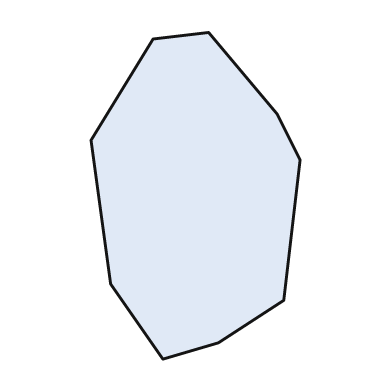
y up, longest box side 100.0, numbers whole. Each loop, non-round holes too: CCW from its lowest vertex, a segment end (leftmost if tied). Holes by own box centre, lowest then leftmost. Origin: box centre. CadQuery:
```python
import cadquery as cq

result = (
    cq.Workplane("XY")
    .moveTo(-10.0, -50.0)
    .lineTo(7.0, -45.0)
    .lineTo(27.0, -32.0)
    .lineTo(32.0, 11.0)
    .lineTo(25.0, 25.0)
    .lineTo(4.0, 50.0)
    .lineTo(-13.0, 48.0)
    .lineTo(-32.0, 17.0)
    .lineTo(-26.0, -27.0)
    .close()
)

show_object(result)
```